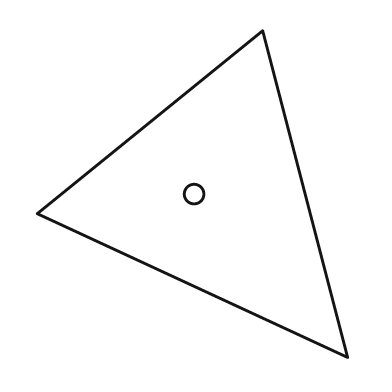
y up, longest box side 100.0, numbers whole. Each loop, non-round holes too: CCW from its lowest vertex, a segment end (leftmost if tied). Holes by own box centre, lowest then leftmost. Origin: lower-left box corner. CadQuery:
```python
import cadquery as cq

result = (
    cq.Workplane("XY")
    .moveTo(95.0, 0.0)
    .lineTo(69.0, 100.0)
    .lineTo(0.0, 44.0)
    .close()
    .moveTo(48.0, 50.0)
    .circle(3.0)
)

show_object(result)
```